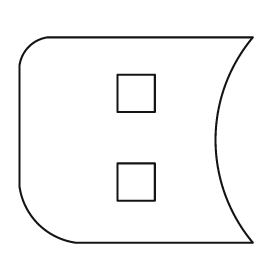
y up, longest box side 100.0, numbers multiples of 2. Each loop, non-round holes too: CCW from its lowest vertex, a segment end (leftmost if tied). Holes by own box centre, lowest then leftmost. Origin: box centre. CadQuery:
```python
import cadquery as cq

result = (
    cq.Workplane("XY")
    .moveTo(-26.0, -44.0)
    .lineTo(50.0, -44.0)
    .threePointArc((34.0, 0.0), (50.0, 44.0))
    .lineTo(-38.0, 44.0)
    .threePointArc((-46.0, 40.0), (-50.0, 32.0))
    .lineTo(-50.0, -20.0)
    .threePointArc((-42.0, -36.0), (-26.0, -44.0))
    .close()
    .moveTo(-8.0, -26.0)
    .lineTo(8.0, -26.0)
    .lineTo(8.0, -10.0)
    .lineTo(-8.0, -10.0)
    .close()
    .moveTo(-8.0, 12.0)
    .lineTo(8.0, 12.0)
    .lineTo(8.0, 28.0)
    .lineTo(-8.0, 28.0)
    .close()
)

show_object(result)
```